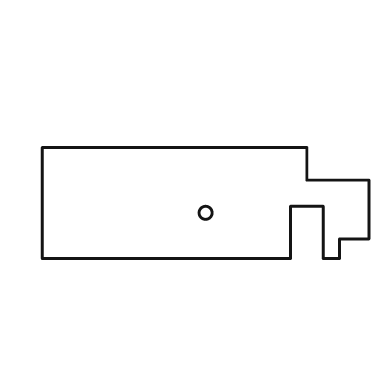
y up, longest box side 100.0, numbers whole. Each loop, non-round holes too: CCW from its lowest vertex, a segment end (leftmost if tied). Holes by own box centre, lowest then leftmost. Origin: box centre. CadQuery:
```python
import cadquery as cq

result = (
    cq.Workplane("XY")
    .moveTo(-50.0, -17.0)
    .lineTo(26.0, -17.0)
    .lineTo(26.0, -1.0)
    .lineTo(36.0, -1.0)
    .lineTo(36.0, -17.0)
    .lineTo(41.0, -17.0)
    .lineTo(41.0, -11.0)
    .lineTo(50.0, -11.0)
    .lineTo(50.0, 7.0)
    .lineTo(31.0, 7.0)
    .lineTo(31.0, 17.0)
    .lineTo(-50.0, 17.0)
    .close()
    .moveTo(0.0, -3.0)
    .circle(2.0)
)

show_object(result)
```